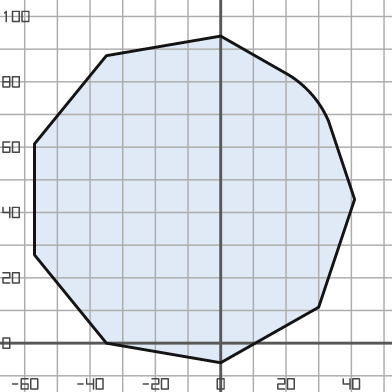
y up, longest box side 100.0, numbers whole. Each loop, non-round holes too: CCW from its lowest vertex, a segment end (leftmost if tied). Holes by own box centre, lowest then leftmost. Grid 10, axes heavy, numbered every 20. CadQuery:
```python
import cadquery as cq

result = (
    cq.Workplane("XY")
    .moveTo(0.0, -6.0)
    .lineTo(30.0, 11.0)
    .lineTo(41.0, 44.0)
    .lineTo(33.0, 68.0)
    .threePointArc((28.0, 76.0), (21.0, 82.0))
    .lineTo(0.0, 94.0)
    .lineTo(-35.0, 88.0)
    .lineTo(-57.0, 61.0)
    .lineTo(-57.0, 27.0)
    .lineTo(-35.0, 0.0)
    .close()
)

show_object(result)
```